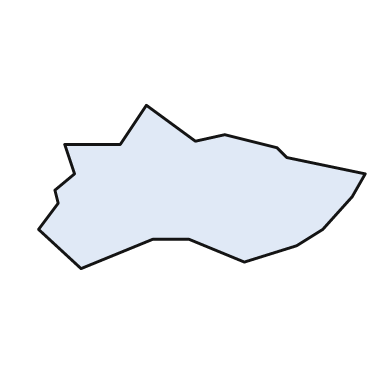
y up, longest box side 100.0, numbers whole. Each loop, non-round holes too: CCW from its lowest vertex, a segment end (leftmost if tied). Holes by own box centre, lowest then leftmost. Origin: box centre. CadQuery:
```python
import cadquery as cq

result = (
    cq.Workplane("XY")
    .moveTo(-37.0, -25.0)
    .lineTo(-15.0, -16.0)
    .lineTo(-4.0, -16.0)
    .lineTo(13.0, -23.0)
    .lineTo(29.0, -18.0)
    .lineTo(37.0, -13.0)
    .lineTo(46.0, -3.0)
    .lineTo(50.0, 4.0)
    .lineTo(26.0, 9.0)
    .lineTo(23.0, 12.0)
    .lineTo(7.0, 16.0)
    .lineTo(-2.0, 14.0)
    .lineTo(-17.0, 25.0)
    .lineTo(-25.0, 13.0)
    .lineTo(-42.0, 13.0)
    .lineTo(-39.0, 4.0)
    .lineTo(-45.0, -1.0)
    .lineTo(-44.0, -5.0)
    .lineTo(-50.0, -13.0)
    .close()
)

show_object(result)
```